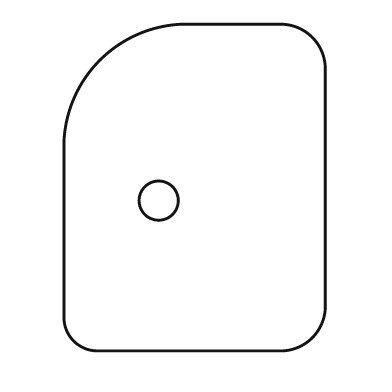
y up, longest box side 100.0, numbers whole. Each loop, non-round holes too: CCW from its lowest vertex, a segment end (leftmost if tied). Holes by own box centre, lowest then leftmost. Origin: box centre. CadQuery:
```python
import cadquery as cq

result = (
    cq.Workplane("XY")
    .moveTo(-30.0, -50.0)
    .lineTo(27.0, -50.0)
    .threePointArc((36.0, -46.0), (40.0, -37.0))
    .lineTo(40.0, 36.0)
    .threePointArc((36.0, 46.0), (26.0, 50.0))
    .lineTo(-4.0, 50.0)
    .threePointArc((-29.0, 39.0), (-40.0, 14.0))
    .lineTo(-40.0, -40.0)
    .threePointArc((-37.0, -47.0), (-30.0, -50.0))
    .close()
    .moveTo(-11.0, -4.0)
    .circle(6.0)
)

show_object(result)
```